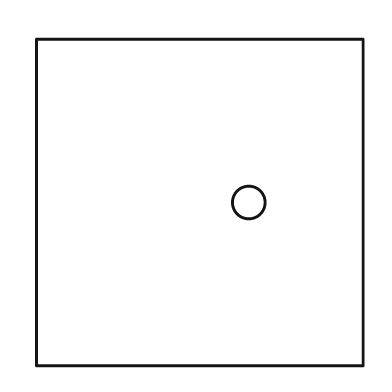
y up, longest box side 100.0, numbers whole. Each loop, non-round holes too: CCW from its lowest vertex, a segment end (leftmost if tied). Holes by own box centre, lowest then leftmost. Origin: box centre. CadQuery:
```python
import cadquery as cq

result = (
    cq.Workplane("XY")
    .moveTo(-50.0, -50.0)
    .lineTo(50.0, -50.0)
    .lineTo(50.0, 50.0)
    .lineTo(-50.0, 50.0)
    .close()
    .moveTo(15.0, 0.0)
    .circle(5.0)
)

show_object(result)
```